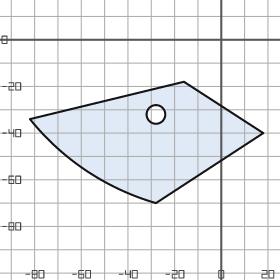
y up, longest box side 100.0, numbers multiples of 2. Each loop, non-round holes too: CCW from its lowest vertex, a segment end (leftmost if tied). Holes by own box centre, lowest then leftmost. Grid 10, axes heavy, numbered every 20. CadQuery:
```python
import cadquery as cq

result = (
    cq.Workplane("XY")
    .moveTo(-28.0, -70.0)
    .lineTo(18.0, -40.0)
    .lineTo(-16.0, -18.0)
    .lineTo(-82.0, -34.0)
    .threePointArc((-58.0, -56.0), (-28.0, -70.0))
    .close()
    .moveTo(-28.0, -32.0)
    .circle(4.0)
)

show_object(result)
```